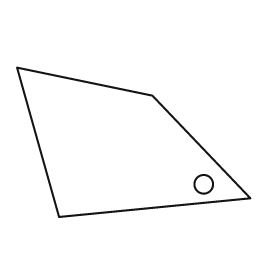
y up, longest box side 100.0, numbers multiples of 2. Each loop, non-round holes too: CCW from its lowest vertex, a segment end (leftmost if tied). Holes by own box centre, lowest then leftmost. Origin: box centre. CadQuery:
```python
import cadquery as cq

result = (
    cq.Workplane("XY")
    .moveTo(-32.0, -32.0)
    .lineTo(50.0, -24.0)
    .lineTo(8.0, 20.0)
    .lineTo(-50.0, 32.0)
    .close()
    .moveTo(30.0, -18.0)
    .circle(4.0)
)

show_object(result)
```